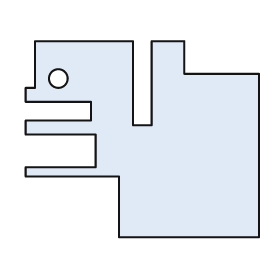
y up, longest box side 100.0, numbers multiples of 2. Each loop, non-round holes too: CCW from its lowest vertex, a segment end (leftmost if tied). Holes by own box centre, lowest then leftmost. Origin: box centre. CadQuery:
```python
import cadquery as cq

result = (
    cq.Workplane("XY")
    .moveTo(-10.0, -42.0)
    .lineTo(50.0, -42.0)
    .lineTo(50.0, 28.0)
    .lineTo(18.0, 28.0)
    .lineTo(18.0, 42.0)
    .lineTo(4.0, 42.0)
    .lineTo(4.0, 6.0)
    .lineTo(-4.0, 6.0)
    .lineTo(-4.0, 42.0)
    .lineTo(-46.0, 42.0)
    .lineTo(-46.0, 22.0)
    .lineTo(-50.0, 22.0)
    .lineTo(-50.0, 16.0)
    .lineTo(-22.0, 16.0)
    .lineTo(-22.0, 8.0)
    .lineTo(-50.0, 8.0)
    .lineTo(-50.0, 2.0)
    .lineTo(-20.0, 2.0)
    .lineTo(-20.0, -12.0)
    .lineTo(-50.0, -12.0)
    .lineTo(-50.0, -16.0)
    .lineTo(-10.0, -16.0)
    .close()
    .moveTo(-36.0, 26.0)
    .circle(4.0)
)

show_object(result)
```